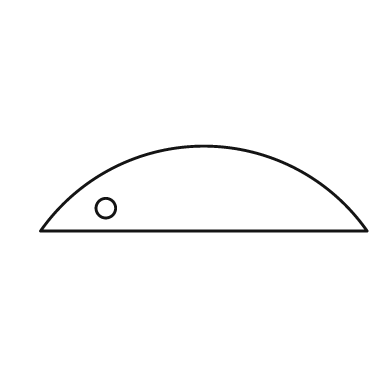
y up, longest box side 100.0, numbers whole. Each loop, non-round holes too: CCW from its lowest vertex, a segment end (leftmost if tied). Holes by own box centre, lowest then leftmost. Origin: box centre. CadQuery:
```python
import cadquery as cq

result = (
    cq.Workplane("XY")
    .moveTo(-50.0, -13.0)
    .lineTo(50.0, -13.0)
    .threePointArc((0.0, 13.0), (-50.0, -13.0))
    .close()
    .moveTo(-30.0, -6.0)
    .circle(3.0)
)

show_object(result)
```